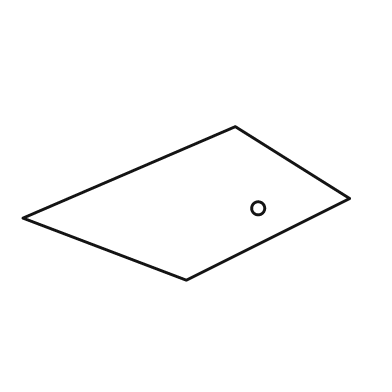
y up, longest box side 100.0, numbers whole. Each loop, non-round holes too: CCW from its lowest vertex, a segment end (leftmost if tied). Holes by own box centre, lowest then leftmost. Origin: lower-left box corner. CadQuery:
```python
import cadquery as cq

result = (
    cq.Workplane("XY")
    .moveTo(50.0, 0.0)
    .lineTo(100.0, 25.0)
    .lineTo(65.0, 47.0)
    .lineTo(0.0, 19.0)
    .close()
    .moveTo(72.0, 22.0)
    .circle(2.0)
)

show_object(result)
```